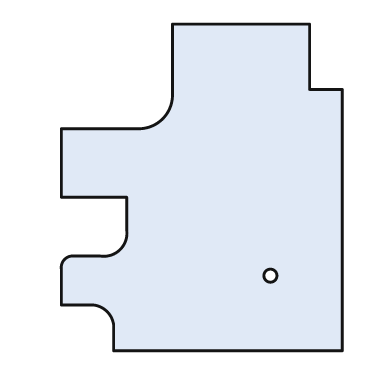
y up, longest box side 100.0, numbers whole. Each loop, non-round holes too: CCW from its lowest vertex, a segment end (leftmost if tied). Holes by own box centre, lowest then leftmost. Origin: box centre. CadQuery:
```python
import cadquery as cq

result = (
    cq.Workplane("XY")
    .moveTo(-27.0, -50.0)
    .lineTo(43.0, -50.0)
    .lineTo(43.0, 30.0)
    .lineTo(33.0, 30.0)
    .lineTo(33.0, 50.0)
    .lineTo(-9.0, 50.0)
    .lineTo(-9.0, 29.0)
    .threePointArc((-12.0, 21.0), (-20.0, 18.0))
    .lineTo(-43.0, 18.0)
    .lineTo(-43.0, -3.0)
    .lineTo(-23.0, -3.0)
    .lineTo(-23.0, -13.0)
    .threePointArc((-25.0, -19.0), (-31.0, -21.0))
    .lineTo(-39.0, -21.0)
    .threePointArc((-42.0, -22.0), (-43.0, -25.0))
    .lineTo(-43.0, -36.0)
    .lineTo(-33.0, -36.0)
    .threePointArc((-29.0, -38.0), (-27.0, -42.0))
    .close()
    .moveTo(21.0, -27.0)
    .circle(2.0)
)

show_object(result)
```